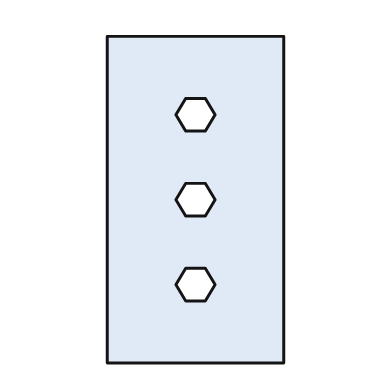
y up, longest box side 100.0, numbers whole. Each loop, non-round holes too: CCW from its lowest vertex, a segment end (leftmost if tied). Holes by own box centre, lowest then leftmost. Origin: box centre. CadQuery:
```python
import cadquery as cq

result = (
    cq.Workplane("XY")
    .moveTo(-27.0, -50.0)
    .lineTo(27.0, -50.0)
    .lineTo(27.0, 50.0)
    .lineTo(-27.0, 50.0)
    .close()
    .moveTo(-3.0, -31.0)
    .lineTo(3.0, -31.0)
    .lineTo(6.0, -26.0)
    .lineTo(3.0, -21.0)
    .lineTo(-3.0, -21.0)
    .lineTo(-6.0, -26.0)
    .close()
    .moveTo(-3.0, -5.0)
    .lineTo(3.0, -5.0)
    .lineTo(6.0, 0.0)
    .lineTo(3.0, 5.0)
    .lineTo(-3.0, 5.0)
    .lineTo(-6.0, 0.0)
    .close()
    .moveTo(-3.0, 21.0)
    .lineTo(3.0, 21.0)
    .lineTo(6.0, 26.0)
    .lineTo(3.0, 31.0)
    .lineTo(-3.0, 31.0)
    .lineTo(-6.0, 26.0)
    .close()
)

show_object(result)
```